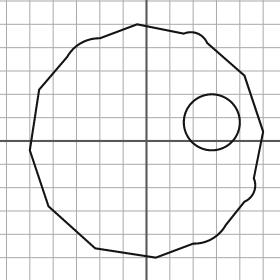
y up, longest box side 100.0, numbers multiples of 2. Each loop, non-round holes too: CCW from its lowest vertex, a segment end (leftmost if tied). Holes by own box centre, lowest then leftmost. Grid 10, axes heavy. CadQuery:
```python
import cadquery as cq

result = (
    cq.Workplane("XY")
    .moveTo(4.0, -50.0)
    .lineTo(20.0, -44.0)
    .threePointArc((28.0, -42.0), (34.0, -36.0))
    .lineTo(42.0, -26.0)
    .threePointArc((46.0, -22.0), (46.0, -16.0))
    .lineTo(50.0, 4.0)
    .lineTo(42.0, 28.0)
    .lineTo(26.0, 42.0)
    .threePointArc((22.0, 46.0), (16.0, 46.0))
    .lineTo(-4.0, 50.0)
    .lineTo(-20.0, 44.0)
    .threePointArc((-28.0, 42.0), (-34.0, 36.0))
    .lineTo(-46.0, 22.0)
    .lineTo(-50.0, -4.0)
    .lineTo(-42.0, -28.0)
    .lineTo(-22.0, -46.0)
    .close()
    .moveTo(28.0, 8.0)
    .circle(12.0)
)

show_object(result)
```